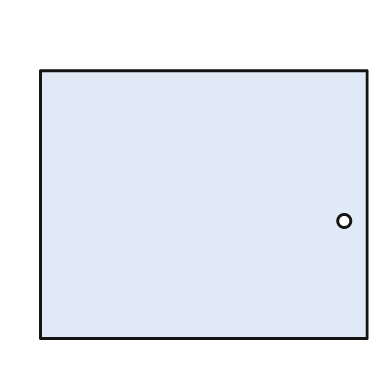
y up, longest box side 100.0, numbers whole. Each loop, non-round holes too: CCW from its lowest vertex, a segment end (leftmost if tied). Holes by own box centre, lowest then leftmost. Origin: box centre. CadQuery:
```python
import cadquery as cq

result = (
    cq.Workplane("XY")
    .moveTo(-50.0, -41.0)
    .lineTo(50.0, -41.0)
    .lineTo(50.0, 41.0)
    .lineTo(-50.0, 41.0)
    .close()
    .moveTo(43.0, -5.0)
    .circle(2.0)
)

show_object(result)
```